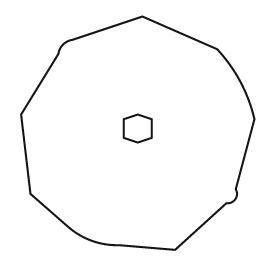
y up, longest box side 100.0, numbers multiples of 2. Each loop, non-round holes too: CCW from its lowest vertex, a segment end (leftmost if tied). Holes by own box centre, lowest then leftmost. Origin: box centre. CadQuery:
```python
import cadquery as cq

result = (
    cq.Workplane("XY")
    .moveTo(16.0, -50.0)
    .lineTo(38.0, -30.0)
    .threePointArc((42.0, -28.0), (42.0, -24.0))
    .lineTo(50.0, 6.0)
    .threePointArc((44.0, 22.0), (34.0, 36.0))
    .lineTo(2.0, 50.0)
    .lineTo(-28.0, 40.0)
    .threePointArc((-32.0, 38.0), (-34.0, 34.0))
    .lineTo(-50.0, 8.0)
    .lineTo(-46.0, -26.0)
    .lineTo(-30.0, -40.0)
    .threePointArc((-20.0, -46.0), (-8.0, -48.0))
    .close()
    .moveTo(0.0, -4.0)
    .lineTo(6.0, -2.0)
    .lineTo(6.0, 6.0)
    .lineTo(0.0, 8.0)
    .lineTo(-6.0, 6.0)
    .lineTo(-6.0, -2.0)
    .close()
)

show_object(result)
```